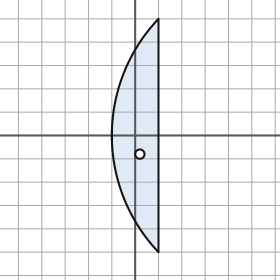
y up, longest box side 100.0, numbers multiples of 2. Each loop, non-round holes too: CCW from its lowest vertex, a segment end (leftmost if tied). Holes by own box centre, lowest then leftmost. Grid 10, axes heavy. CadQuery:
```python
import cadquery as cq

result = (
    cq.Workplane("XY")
    .moveTo(10.0, -50.0)
    .lineTo(10.0, 50.0)
    .threePointArc((-10.0, 0.0), (10.0, -50.0))
    .close()
    .moveTo(2.0, -8.0)
    .circle(2.0)
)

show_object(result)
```